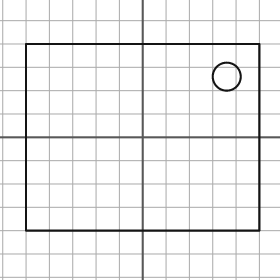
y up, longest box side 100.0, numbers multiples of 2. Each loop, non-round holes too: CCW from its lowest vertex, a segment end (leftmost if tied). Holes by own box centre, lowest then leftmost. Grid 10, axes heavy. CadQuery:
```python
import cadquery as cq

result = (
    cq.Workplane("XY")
    .moveTo(-50.0, -40.0)
    .lineTo(50.0, -40.0)
    .lineTo(50.0, 40.0)
    .lineTo(-50.0, 40.0)
    .close()
    .moveTo(36.0, 26.0)
    .circle(6.0)
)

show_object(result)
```